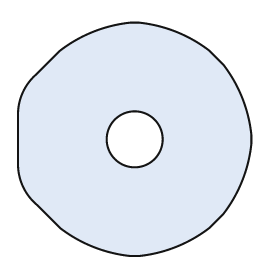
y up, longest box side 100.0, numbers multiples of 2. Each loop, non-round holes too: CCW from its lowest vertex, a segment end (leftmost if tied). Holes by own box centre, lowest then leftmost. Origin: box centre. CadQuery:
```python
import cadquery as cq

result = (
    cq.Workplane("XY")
    .moveTo(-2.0, -50.0)
    .lineTo(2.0, -50.0)
    .threePointArc((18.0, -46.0), (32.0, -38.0))
    .lineTo(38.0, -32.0)
    .threePointArc((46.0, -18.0), (50.0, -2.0))
    .lineTo(50.0, 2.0)
    .threePointArc((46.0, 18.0), (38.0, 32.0))
    .lineTo(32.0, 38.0)
    .threePointArc((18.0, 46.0), (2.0, 50.0))
    .lineTo(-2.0, 50.0)
    .threePointArc((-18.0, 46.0), (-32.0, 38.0))
    .lineTo(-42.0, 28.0)
    .threePointArc((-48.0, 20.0), (-50.0, 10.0))
    .lineTo(-50.0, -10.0)
    .threePointArc((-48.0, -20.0), (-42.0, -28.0))
    .lineTo(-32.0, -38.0)
    .threePointArc((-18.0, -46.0), (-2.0, -50.0))
    .close()
    .moveTo(0.0, 0.0)
    .circle(12.0)
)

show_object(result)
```